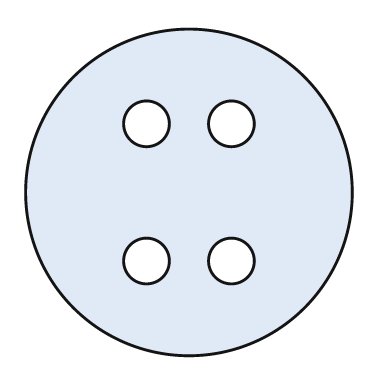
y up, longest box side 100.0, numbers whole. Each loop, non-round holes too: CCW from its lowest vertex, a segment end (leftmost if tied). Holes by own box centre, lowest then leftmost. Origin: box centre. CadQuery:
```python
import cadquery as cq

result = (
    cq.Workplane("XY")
    .moveTo(0.0, 0.0)
    .circle(50.0)
    .moveTo(-13.0, -21.0)
    .circle(7.0)
    .moveTo(13.0, -21.0)
    .circle(7.0)
    .moveTo(-13.0, 21.0)
    .circle(7.0)
    .moveTo(13.0, 21.0)
    .circle(7.0)
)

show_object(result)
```